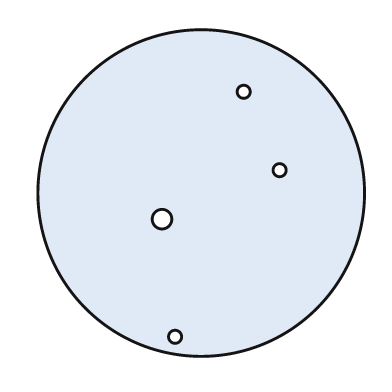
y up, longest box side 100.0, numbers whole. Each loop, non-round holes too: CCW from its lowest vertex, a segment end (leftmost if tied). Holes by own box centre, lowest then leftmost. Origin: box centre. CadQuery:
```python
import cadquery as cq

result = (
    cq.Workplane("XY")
    .moveTo(0.0, 0.0)
    .circle(50.0)
    .moveTo(-8.0, -44.0)
    .circle(2.0)
    .moveTo(-12.0, -8.0)
    .circle(3.0)
    .moveTo(24.0, 7.0)
    .circle(2.0)
    .moveTo(13.0, 31.0)
    .circle(2.0)
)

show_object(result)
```